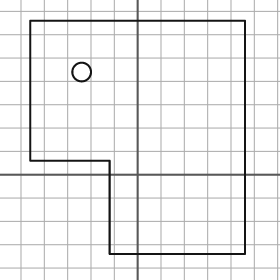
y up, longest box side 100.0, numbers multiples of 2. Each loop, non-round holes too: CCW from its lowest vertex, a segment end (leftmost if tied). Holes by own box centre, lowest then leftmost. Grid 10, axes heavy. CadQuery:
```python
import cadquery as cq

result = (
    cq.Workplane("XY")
    .moveTo(-12.0, -34.0)
    .lineTo(46.0, -34.0)
    .lineTo(46.0, 66.0)
    .lineTo(-46.0, 66.0)
    .lineTo(-46.0, 6.0)
    .lineTo(-12.0, 6.0)
    .close()
    .moveTo(-24.0, 44.0)
    .circle(4.0)
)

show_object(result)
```